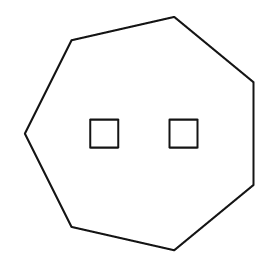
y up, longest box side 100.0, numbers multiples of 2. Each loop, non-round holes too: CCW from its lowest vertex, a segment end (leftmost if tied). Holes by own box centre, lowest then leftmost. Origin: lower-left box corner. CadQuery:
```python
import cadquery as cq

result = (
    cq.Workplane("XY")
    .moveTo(64.0, 0.0)
    .lineTo(98.0, 28.0)
    .lineTo(98.0, 72.0)
    .lineTo(64.0, 100.0)
    .lineTo(20.0, 90.0)
    .lineTo(0.0, 50.0)
    .lineTo(20.0, 10.0)
    .close()
    .moveTo(28.0, 44.0)
    .lineTo(40.0, 44.0)
    .lineTo(40.0, 56.0)
    .lineTo(28.0, 56.0)
    .close()
    .moveTo(62.0, 44.0)
    .lineTo(74.0, 44.0)
    .lineTo(74.0, 56.0)
    .lineTo(62.0, 56.0)
    .close()
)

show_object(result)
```